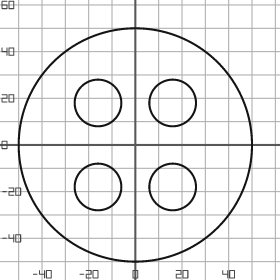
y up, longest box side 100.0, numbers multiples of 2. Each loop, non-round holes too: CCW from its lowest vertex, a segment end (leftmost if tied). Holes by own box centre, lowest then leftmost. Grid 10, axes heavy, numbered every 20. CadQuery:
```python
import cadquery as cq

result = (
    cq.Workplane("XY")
    .moveTo(0.0, 0.0)
    .circle(50.0)
    .moveTo(-16.0, -18.0)
    .circle(10.0)
    .moveTo(16.0, -18.0)
    .circle(10.0)
    .moveTo(-16.0, 18.0)
    .circle(10.0)
    .moveTo(16.0, 18.0)
    .circle(10.0)
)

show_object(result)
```